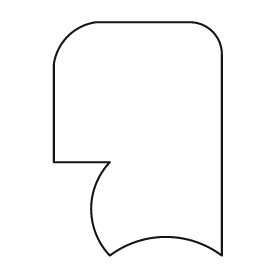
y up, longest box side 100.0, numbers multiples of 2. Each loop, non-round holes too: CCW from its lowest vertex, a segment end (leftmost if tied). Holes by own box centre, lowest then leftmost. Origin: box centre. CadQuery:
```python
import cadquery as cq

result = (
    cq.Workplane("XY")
    .moveTo(-12.0, -50.0)
    .threePointArc((12.0, -42.0), (36.0, -50.0))
    .lineTo(36.0, 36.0)
    .threePointArc((32.0, 46.0), (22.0, 50.0))
    .lineTo(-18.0, 50.0)
    .threePointArc((-30.0, 44.0), (-36.0, 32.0))
    .lineTo(-36.0, -10.0)
    .lineTo(-12.0, -10.0)
    .threePointArc((-20.0, -30.0), (-12.0, -50.0))
    .close()
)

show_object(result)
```